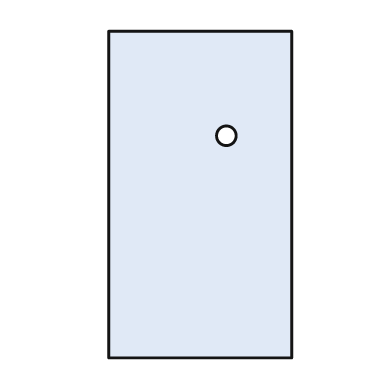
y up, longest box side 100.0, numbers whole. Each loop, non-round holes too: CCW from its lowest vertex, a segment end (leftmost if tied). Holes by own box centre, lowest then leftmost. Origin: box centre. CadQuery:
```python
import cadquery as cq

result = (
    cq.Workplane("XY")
    .moveTo(-28.0, -50.0)
    .lineTo(28.0, -50.0)
    .lineTo(28.0, 50.0)
    .lineTo(-28.0, 50.0)
    .close()
    .moveTo(8.0, 18.0)
    .circle(3.0)
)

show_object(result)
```